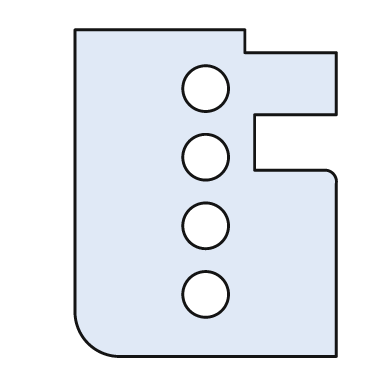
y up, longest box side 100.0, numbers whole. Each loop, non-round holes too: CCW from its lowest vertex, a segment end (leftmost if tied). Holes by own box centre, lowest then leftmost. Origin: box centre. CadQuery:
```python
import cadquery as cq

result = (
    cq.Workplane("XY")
    .moveTo(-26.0, -50.0)
    .lineTo(40.0, -50.0)
    .lineTo(40.0, 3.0)
    .threePointArc((39.0, 6.0), (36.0, 7.0))
    .lineTo(15.0, 7.0)
    .lineTo(15.0, 24.0)
    .lineTo(40.0, 24.0)
    .lineTo(40.0, 43.0)
    .lineTo(12.0, 43.0)
    .lineTo(12.0, 50.0)
    .lineTo(-40.0, 50.0)
    .lineTo(-40.0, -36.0)
    .threePointArc((-36.0, -46.0), (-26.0, -50.0))
    .close()
    .moveTo(0.0, -31.0)
    .circle(7.0)
    .moveTo(0.0, -10.0)
    .circle(7.0)
    .moveTo(0.0, 11.0)
    .circle(7.0)
    .moveTo(0.0, 32.0)
    .circle(7.0)
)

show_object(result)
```